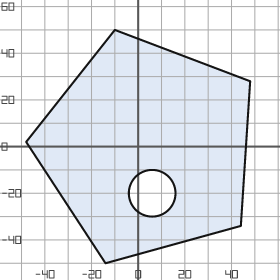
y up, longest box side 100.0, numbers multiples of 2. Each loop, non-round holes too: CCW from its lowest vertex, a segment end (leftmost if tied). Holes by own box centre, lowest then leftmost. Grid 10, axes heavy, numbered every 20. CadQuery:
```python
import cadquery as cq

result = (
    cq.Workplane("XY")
    .moveTo(-14.0, -50.0)
    .lineTo(44.0, -34.0)
    .lineTo(48.0, 28.0)
    .lineTo(-10.0, 50.0)
    .lineTo(-48.0, 2.0)
    .close()
    .moveTo(6.0, -20.0)
    .circle(10.0)
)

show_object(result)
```